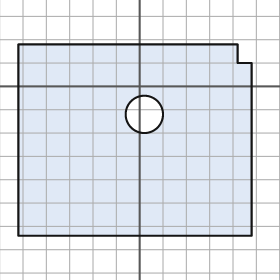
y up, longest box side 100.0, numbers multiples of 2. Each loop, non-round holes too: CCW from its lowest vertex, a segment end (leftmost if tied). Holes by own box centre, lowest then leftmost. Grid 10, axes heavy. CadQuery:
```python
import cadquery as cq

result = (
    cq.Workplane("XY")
    .moveTo(-52.0, -64.0)
    .lineTo(48.0, -64.0)
    .lineTo(48.0, 10.0)
    .lineTo(42.0, 10.0)
    .lineTo(42.0, 18.0)
    .lineTo(-52.0, 18.0)
    .close()
    .moveTo(2.0, -12.0)
    .circle(8.0)
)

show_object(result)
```